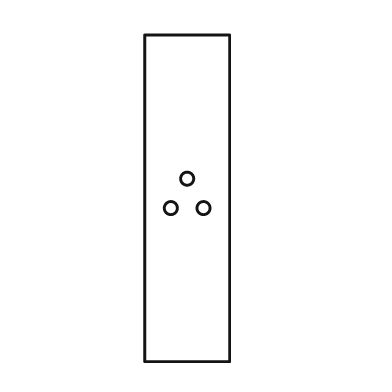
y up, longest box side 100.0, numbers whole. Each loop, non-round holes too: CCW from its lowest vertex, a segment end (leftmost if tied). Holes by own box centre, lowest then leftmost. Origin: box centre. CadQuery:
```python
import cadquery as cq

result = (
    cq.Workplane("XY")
    .moveTo(-13.0, -50.0)
    .lineTo(13.0, -50.0)
    .lineTo(13.0, 50.0)
    .lineTo(-13.0, 50.0)
    .close()
    .moveTo(-5.0, -3.0)
    .circle(2.0)
    .moveTo(5.0, -3.0)
    .circle(2.0)
    .moveTo(0.0, 6.0)
    .circle(2.0)
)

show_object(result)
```